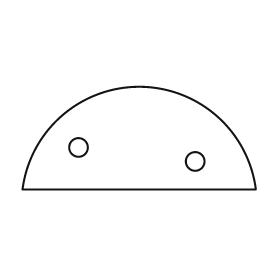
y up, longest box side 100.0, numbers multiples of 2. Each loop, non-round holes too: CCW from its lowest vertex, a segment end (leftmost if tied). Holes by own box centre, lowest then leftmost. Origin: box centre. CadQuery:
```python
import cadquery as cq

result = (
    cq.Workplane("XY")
    .moveTo(-50.0, -22.0)
    .lineTo(50.0, -22.0)
    .threePointArc((0.0, 22.0), (-50.0, -22.0))
    .close()
    .moveTo(24.0, -10.0)
    .circle(4.0)
    .moveTo(-26.0, -4.0)
    .circle(4.0)
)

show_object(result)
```